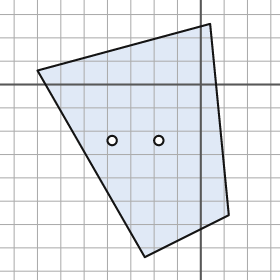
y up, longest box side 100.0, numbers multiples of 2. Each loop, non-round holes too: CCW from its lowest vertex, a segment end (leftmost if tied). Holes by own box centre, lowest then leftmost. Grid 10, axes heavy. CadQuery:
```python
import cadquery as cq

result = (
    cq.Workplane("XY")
    .moveTo(-24.0, -74.0)
    .lineTo(12.0, -56.0)
    .lineTo(4.0, 26.0)
    .lineTo(-70.0, 6.0)
    .close()
    .moveTo(-38.0, -24.0)
    .circle(2.0)
    .moveTo(-18.0, -24.0)
    .circle(2.0)
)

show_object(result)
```